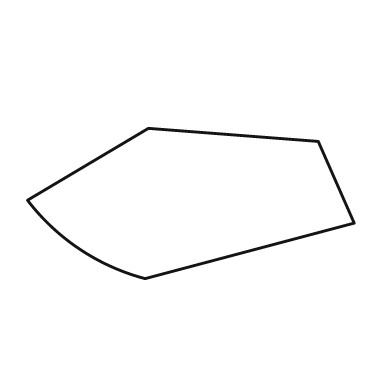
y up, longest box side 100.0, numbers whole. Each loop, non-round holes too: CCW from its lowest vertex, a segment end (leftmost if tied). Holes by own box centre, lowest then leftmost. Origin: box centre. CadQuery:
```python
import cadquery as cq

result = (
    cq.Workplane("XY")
    .moveTo(-14.0, -23.0)
    .lineTo(50.0, -6.0)
    .lineTo(39.0, 19.0)
    .lineTo(-13.0, 23.0)
    .lineTo(-50.0, 1.0)
    .threePointArc((-34.0, -14.0), (-14.0, -23.0))
    .close()
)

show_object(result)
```